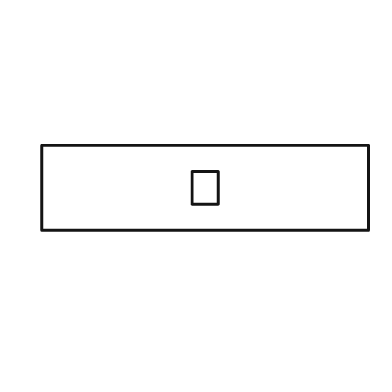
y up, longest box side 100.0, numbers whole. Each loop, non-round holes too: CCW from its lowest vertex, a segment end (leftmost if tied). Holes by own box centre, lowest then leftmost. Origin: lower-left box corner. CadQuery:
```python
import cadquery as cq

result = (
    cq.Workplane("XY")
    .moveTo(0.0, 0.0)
    .lineTo(100.0, 0.0)
    .lineTo(100.0, 26.0)
    .lineTo(0.0, 26.0)
    .close()
    .moveTo(46.0, 8.0)
    .lineTo(54.0, 8.0)
    .lineTo(54.0, 18.0)
    .lineTo(46.0, 18.0)
    .close()
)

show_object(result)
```